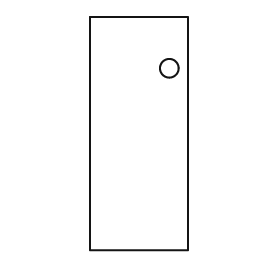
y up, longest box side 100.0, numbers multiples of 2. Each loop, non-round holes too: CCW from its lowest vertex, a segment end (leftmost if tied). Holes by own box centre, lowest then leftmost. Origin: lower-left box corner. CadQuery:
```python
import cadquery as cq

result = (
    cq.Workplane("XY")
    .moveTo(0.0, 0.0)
    .lineTo(42.0, 0.0)
    .lineTo(42.0, 100.0)
    .lineTo(0.0, 100.0)
    .close()
    .moveTo(34.0, 78.0)
    .circle(4.0)
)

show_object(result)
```